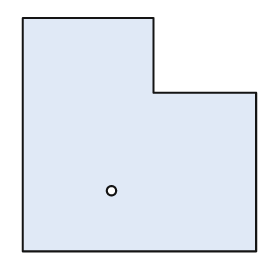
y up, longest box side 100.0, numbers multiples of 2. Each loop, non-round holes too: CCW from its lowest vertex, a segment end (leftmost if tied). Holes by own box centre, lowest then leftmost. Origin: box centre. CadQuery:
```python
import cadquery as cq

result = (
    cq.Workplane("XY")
    .moveTo(-50.0, -50.0)
    .lineTo(50.0, -50.0)
    .lineTo(50.0, 18.0)
    .lineTo(6.0, 18.0)
    .lineTo(6.0, 50.0)
    .lineTo(-50.0, 50.0)
    .close()
    .moveTo(-12.0, -24.0)
    .circle(2.0)
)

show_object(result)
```